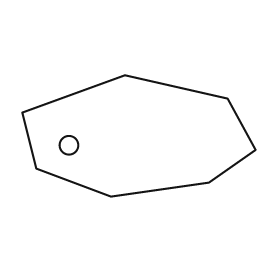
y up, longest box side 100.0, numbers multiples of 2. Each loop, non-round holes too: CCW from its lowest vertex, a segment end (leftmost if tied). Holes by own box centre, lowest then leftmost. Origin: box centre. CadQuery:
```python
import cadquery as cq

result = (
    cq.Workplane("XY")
    .moveTo(-12.0, -26.0)
    .lineTo(30.0, -20.0)
    .lineTo(50.0, -6.0)
    .lineTo(38.0, 16.0)
    .lineTo(-6.0, 26.0)
    .lineTo(-50.0, 10.0)
    .lineTo(-44.0, -14.0)
    .close()
    .moveTo(-30.0, -4.0)
    .circle(4.0)
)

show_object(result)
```